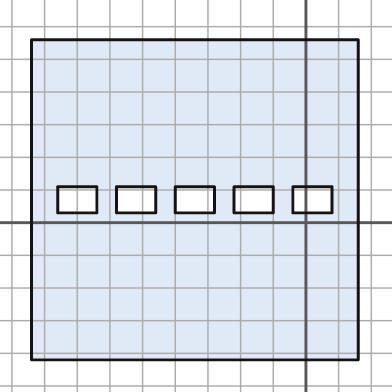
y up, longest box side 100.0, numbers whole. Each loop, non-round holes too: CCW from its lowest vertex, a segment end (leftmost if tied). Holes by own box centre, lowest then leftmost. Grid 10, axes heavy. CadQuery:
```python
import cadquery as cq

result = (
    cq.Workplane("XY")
    .moveTo(-84.0, -42.0)
    .lineTo(16.0, -42.0)
    .lineTo(16.0, 56.0)
    .lineTo(-84.0, 56.0)
    .close()
    .moveTo(-76.0, 3.0)
    .lineTo(-64.0, 3.0)
    .lineTo(-64.0, 11.0)
    .lineTo(-76.0, 11.0)
    .close()
    .moveTo(-58.0, 3.0)
    .lineTo(-46.0, 3.0)
    .lineTo(-46.0, 11.0)
    .lineTo(-58.0, 11.0)
    .close()
    .moveTo(-40.0, 3.0)
    .lineTo(-28.0, 3.0)
    .lineTo(-28.0, 11.0)
    .lineTo(-40.0, 11.0)
    .close()
    .moveTo(-22.0, 3.0)
    .lineTo(-10.0, 3.0)
    .lineTo(-10.0, 11.0)
    .lineTo(-22.0, 11.0)
    .close()
    .moveTo(-4.0, 3.0)
    .lineTo(8.0, 3.0)
    .lineTo(8.0, 11.0)
    .lineTo(-4.0, 11.0)
    .close()
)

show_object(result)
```